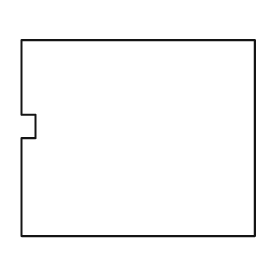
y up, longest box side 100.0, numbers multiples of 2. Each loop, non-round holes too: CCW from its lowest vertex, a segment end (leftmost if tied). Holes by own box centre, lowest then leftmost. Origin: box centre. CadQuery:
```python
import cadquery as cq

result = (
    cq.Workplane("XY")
    .moveTo(-50.0, -42.0)
    .lineTo(50.0, -42.0)
    .lineTo(50.0, 42.0)
    .lineTo(-50.0, 42.0)
    .lineTo(-50.0, 10.0)
    .lineTo(-44.0, 10.0)
    .lineTo(-44.0, 0.0)
    .lineTo(-50.0, 0.0)
    .close()
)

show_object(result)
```